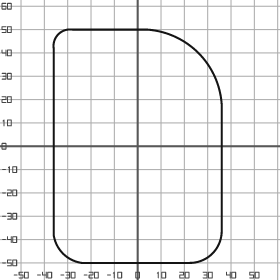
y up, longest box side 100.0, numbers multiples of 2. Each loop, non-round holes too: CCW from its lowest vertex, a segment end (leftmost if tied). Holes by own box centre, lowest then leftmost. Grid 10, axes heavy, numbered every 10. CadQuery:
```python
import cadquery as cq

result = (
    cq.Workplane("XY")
    .moveTo(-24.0, -50.0)
    .lineTo(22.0, -50.0)
    .threePointArc((32.0, -46.0), (36.0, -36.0))
    .lineTo(36.0, 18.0)
    .threePointArc((26.0, 40.0), (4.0, 50.0))
    .lineTo(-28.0, 50.0)
    .threePointArc((-34.0, 48.0), (-36.0, 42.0))
    .lineTo(-36.0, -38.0)
    .threePointArc((-32.0, -46.0), (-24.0, -50.0))
    .close()
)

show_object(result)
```